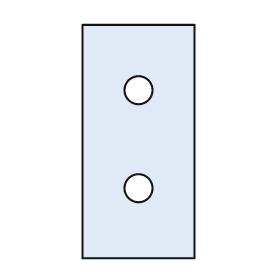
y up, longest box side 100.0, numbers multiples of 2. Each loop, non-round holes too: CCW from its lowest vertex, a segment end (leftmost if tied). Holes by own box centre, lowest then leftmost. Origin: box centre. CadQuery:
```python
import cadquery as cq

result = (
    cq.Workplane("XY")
    .moveTo(-24.0, -50.0)
    .lineTo(24.0, -50.0)
    .lineTo(24.0, 50.0)
    .lineTo(-24.0, 50.0)
    .close()
    .moveTo(0.0, -20.0)
    .circle(6.0)
    .moveTo(0.0, 22.0)
    .circle(6.0)
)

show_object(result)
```